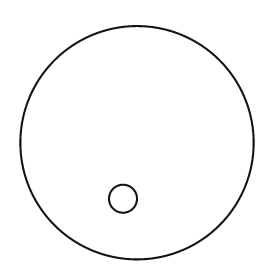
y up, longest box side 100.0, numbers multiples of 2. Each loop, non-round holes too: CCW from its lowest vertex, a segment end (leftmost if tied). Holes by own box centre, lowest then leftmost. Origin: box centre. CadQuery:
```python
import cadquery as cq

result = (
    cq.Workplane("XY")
    .moveTo(0.0, 0.0)
    .circle(50.0)
    .moveTo(-6.0, -24.0)
    .circle(6.0)
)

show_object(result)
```